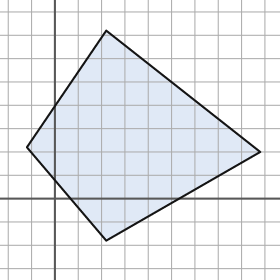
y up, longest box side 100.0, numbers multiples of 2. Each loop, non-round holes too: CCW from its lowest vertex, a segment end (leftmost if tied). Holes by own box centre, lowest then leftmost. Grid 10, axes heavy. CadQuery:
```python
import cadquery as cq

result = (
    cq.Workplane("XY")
    .moveTo(22.0, -18.0)
    .lineTo(88.0, 20.0)
    .lineTo(22.0, 72.0)
    .lineTo(-12.0, 22.0)
    .close()
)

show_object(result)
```